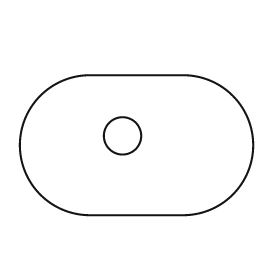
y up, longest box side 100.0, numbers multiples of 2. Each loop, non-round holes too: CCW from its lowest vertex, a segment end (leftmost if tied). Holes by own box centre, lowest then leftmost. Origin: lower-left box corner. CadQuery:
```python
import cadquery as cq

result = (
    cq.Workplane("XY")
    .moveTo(30.0, 0.0)
    .lineTo(70.0, 0.0)
    .threePointArc((100.0, 30.0), (70.0, 60.0))
    .lineTo(30.0, 60.0)
    .threePointArc((0.0, 30.0), (30.0, 0.0))
    .close()
    .moveTo(44.0, 34.0)
    .circle(8.0)
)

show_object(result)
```